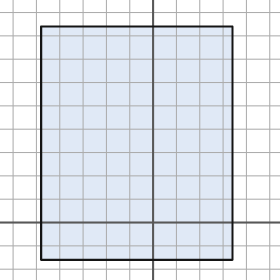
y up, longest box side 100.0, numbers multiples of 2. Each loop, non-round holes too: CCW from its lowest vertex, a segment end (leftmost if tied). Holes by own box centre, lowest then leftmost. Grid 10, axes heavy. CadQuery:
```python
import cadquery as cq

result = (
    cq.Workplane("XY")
    .moveTo(-48.0, -16.0)
    .lineTo(34.0, -16.0)
    .lineTo(34.0, 84.0)
    .lineTo(-48.0, 84.0)
    .close()
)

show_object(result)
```